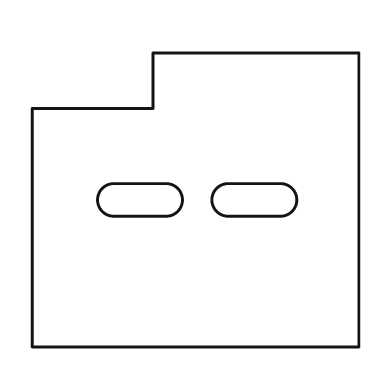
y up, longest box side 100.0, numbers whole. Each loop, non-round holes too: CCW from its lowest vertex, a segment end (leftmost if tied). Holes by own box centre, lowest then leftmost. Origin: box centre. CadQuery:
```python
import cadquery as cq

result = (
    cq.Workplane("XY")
    .moveTo(-50.0, -45.0)
    .lineTo(50.0, -45.0)
    .lineTo(50.0, 45.0)
    .lineTo(-13.0, 45.0)
    .lineTo(-13.0, 28.0)
    .lineTo(-50.0, 28.0)
    .close()
    .moveTo(-25.0, -5.0)
    .lineTo(-9.0, -5.0)
    .threePointArc((-4.0, 0.0), (-9.0, 5.0))
    .lineTo(-25.0, 5.0)
    .threePointArc((-30.0, 0.0), (-25.0, -5.0))
    .close()
    .moveTo(10.0, -5.0)
    .lineTo(26.0, -5.0)
    .threePointArc((31.0, 0.0), (26.0, 5.0))
    .lineTo(10.0, 5.0)
    .threePointArc((5.0, 0.0), (10.0, -5.0))
    .close()
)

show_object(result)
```